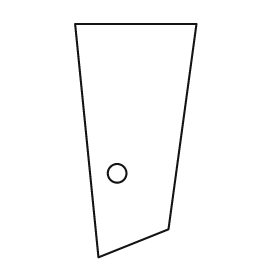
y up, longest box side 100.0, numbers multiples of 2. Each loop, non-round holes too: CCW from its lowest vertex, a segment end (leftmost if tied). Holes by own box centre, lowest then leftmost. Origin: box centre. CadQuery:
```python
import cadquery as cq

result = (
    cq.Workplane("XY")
    .moveTo(-16.0, -50.0)
    .lineTo(14.0, -38.0)
    .lineTo(26.0, 50.0)
    .lineTo(-26.0, 50.0)
    .close()
    .moveTo(-8.0, -14.0)
    .circle(4.0)
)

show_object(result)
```